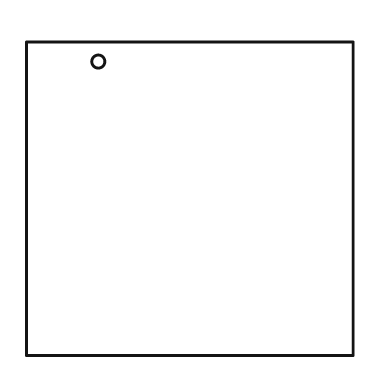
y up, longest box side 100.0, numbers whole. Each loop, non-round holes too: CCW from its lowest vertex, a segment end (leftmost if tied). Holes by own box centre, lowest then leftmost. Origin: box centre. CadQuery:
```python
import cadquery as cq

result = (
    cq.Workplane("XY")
    .moveTo(-50.0, -48.0)
    .lineTo(50.0, -48.0)
    .lineTo(50.0, 48.0)
    .lineTo(-50.0, 48.0)
    .close()
    .moveTo(-28.0, 42.0)
    .circle(2.0)
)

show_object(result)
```